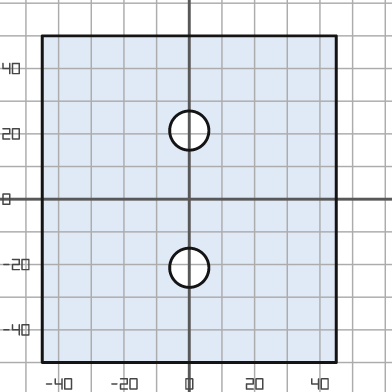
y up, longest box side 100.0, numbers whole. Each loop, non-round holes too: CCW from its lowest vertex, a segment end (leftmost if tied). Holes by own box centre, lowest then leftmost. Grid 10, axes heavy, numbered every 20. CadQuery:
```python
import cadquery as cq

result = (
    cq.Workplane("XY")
    .moveTo(-45.0, -50.0)
    .lineTo(45.0, -50.0)
    .lineTo(45.0, 50.0)
    .lineTo(-45.0, 50.0)
    .close()
    .moveTo(0.0, -21.0)
    .circle(6.0)
    .moveTo(0.0, 21.0)
    .circle(6.0)
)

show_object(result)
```